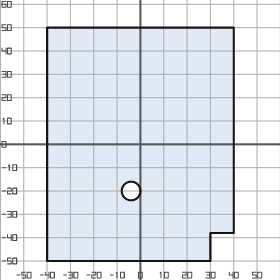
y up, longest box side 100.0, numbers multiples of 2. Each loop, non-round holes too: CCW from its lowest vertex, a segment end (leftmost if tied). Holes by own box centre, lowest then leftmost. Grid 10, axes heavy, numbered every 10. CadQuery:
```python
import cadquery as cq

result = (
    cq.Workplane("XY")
    .moveTo(-40.0, -50.0)
    .lineTo(30.0, -50.0)
    .lineTo(30.0, -38.0)
    .lineTo(40.0, -38.0)
    .lineTo(40.0, 50.0)
    .lineTo(-40.0, 50.0)
    .close()
    .moveTo(-4.0, -20.0)
    .circle(4.0)
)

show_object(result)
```